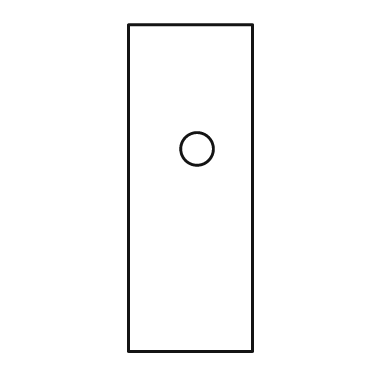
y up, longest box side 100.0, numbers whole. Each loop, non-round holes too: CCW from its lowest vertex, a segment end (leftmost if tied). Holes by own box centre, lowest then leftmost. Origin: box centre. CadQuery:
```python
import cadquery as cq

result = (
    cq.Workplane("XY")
    .moveTo(-19.0, -50.0)
    .lineTo(19.0, -50.0)
    .lineTo(19.0, 50.0)
    .lineTo(-19.0, 50.0)
    .close()
    .moveTo(2.0, 12.0)
    .circle(5.0)
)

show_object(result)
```